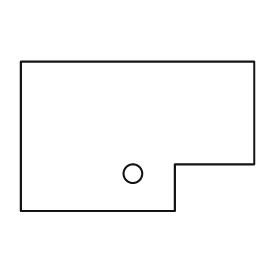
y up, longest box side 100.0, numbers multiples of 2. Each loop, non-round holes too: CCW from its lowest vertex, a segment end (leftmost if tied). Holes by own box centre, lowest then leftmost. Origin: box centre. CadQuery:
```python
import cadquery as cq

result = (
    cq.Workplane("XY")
    .moveTo(-50.0, -32.0)
    .lineTo(16.0, -32.0)
    .lineTo(16.0, -12.0)
    .lineTo(50.0, -12.0)
    .lineTo(50.0, 32.0)
    .lineTo(-50.0, 32.0)
    .close()
    .moveTo(-2.0, -16.0)
    .circle(4.0)
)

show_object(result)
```